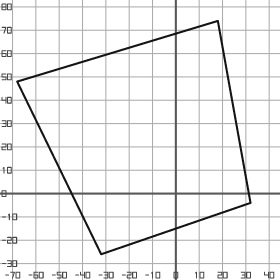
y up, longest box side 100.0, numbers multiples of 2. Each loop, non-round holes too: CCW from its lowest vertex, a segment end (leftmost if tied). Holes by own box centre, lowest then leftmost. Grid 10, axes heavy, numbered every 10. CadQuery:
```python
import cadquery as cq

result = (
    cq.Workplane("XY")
    .moveTo(-32.0, -26.0)
    .lineTo(32.0, -4.0)
    .lineTo(18.0, 74.0)
    .lineTo(-68.0, 48.0)
    .close()
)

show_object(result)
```